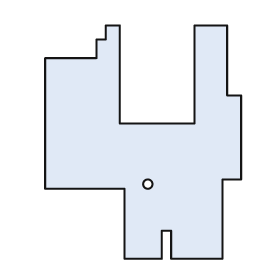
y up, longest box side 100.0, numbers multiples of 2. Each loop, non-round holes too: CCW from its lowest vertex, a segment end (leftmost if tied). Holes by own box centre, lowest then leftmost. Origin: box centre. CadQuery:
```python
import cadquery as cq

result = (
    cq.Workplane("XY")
    .moveTo(-8.0, -50.0)
    .lineTo(8.0, -50.0)
    .lineTo(8.0, -38.0)
    .lineTo(12.0, -38.0)
    .lineTo(12.0, -50.0)
    .lineTo(34.0, -50.0)
    .lineTo(34.0, -16.0)
    .lineTo(42.0, -16.0)
    .lineTo(42.0, 20.0)
    .lineTo(36.0, 20.0)
    .lineTo(36.0, 50.0)
    .lineTo(22.0, 50.0)
    .lineTo(22.0, 8.0)
    .lineTo(-10.0, 8.0)
    .lineTo(-10.0, 50.0)
    .lineTo(-16.0, 50.0)
    .lineTo(-16.0, 44.0)
    .lineTo(-20.0, 44.0)
    .lineTo(-20.0, 36.0)
    .lineTo(-42.0, 36.0)
    .lineTo(-42.0, -20.0)
    .lineTo(-8.0, -20.0)
    .close()
    .moveTo(2.0, -18.0)
    .circle(2.0)
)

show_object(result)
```